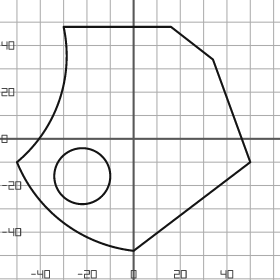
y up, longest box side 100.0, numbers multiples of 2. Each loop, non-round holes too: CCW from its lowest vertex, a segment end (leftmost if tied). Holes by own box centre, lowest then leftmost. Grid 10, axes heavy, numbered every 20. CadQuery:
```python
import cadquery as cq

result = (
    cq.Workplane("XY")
    .moveTo(0.0, -48.0)
    .lineTo(50.0, -10.0)
    .lineTo(34.0, 34.0)
    .lineTo(16.0, 48.0)
    .lineTo(-30.0, 48.0)
    .threePointArc((-32.0, 16.0), (-50.0, -10.0))
    .threePointArc((-30.0, -36.0), (0.0, -48.0))
    .close()
    .moveTo(-22.0, -16.0)
    .circle(12.0)
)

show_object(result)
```